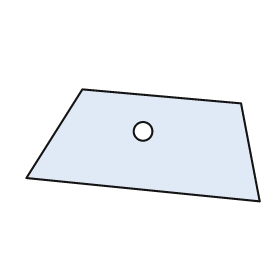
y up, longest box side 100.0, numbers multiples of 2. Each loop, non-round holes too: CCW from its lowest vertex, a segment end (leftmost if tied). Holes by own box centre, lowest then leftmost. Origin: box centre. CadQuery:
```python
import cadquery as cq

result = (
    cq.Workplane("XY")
    .moveTo(50.0, -24.0)
    .lineTo(42.0, 18.0)
    .lineTo(-26.0, 24.0)
    .lineTo(-50.0, -14.0)
    .close()
    .moveTo(0.0, 6.0)
    .circle(4.0)
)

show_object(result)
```